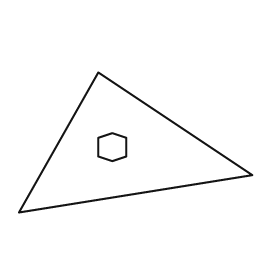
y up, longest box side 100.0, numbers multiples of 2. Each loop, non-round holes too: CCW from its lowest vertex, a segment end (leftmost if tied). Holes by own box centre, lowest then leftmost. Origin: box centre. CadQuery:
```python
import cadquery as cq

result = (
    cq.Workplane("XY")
    .moveTo(-50.0, -30.0)
    .lineTo(50.0, -14.0)
    .lineTo(-16.0, 30.0)
    .close()
    .moveTo(-10.0, -8.0)
    .lineTo(-4.0, -6.0)
    .lineTo(-4.0, 2.0)
    .lineTo(-10.0, 4.0)
    .lineTo(-16.0, 2.0)
    .lineTo(-16.0, -6.0)
    .close()
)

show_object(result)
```